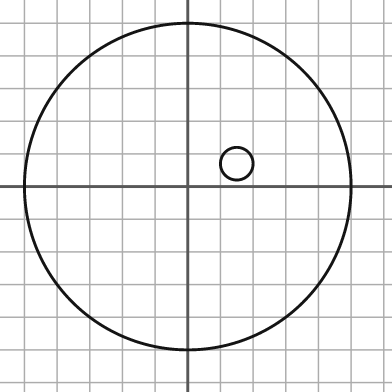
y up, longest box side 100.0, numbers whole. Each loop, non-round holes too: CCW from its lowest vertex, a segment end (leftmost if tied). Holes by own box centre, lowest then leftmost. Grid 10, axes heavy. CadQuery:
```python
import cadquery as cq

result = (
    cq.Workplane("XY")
    .moveTo(0.0, 0.0)
    .circle(50.0)
    .moveTo(15.0, 7.0)
    .circle(5.0)
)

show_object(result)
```